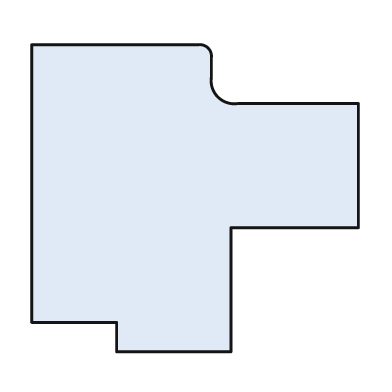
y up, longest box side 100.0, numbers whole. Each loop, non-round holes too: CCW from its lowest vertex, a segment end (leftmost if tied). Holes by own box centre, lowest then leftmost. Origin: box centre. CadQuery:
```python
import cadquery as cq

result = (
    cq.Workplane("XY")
    .moveTo(-24.0, -47.0)
    .lineTo(11.0, -47.0)
    .lineTo(11.0, -9.0)
    .lineTo(50.0, -9.0)
    .lineTo(50.0, 29.0)
    .lineTo(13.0, 29.0)
    .threePointArc((7.0, 31.0), (5.0, 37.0))
    .lineTo(5.0, 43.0)
    .threePointArc((4.0, 46.0), (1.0, 47.0))
    .lineTo(-50.0, 47.0)
    .lineTo(-50.0, -38.0)
    .lineTo(-24.0, -38.0)
    .close()
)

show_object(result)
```